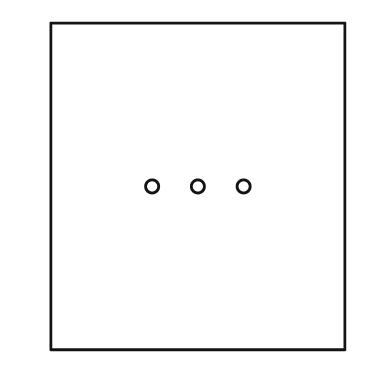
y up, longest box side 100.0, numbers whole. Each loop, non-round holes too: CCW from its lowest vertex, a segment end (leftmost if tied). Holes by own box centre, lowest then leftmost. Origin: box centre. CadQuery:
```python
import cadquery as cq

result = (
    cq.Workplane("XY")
    .moveTo(-45.0, -50.0)
    .lineTo(45.0, -50.0)
    .lineTo(45.0, 50.0)
    .lineTo(-45.0, 50.0)
    .close()
    .moveTo(-14.0, 0.0)
    .circle(2.0)
    .moveTo(0.0, 0.0)
    .circle(2.0)
    .moveTo(14.0, 0.0)
    .circle(2.0)
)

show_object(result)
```